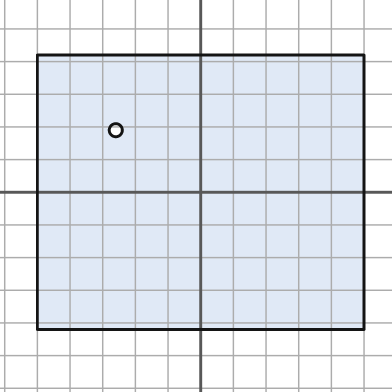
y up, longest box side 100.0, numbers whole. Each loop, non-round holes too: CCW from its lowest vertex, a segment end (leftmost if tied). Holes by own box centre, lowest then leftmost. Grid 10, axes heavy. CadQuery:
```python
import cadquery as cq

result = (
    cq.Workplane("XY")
    .moveTo(-50.0, -42.0)
    .lineTo(50.0, -42.0)
    .lineTo(50.0, 42.0)
    .lineTo(-50.0, 42.0)
    .close()
    .moveTo(-26.0, 19.0)
    .circle(2.0)
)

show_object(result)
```